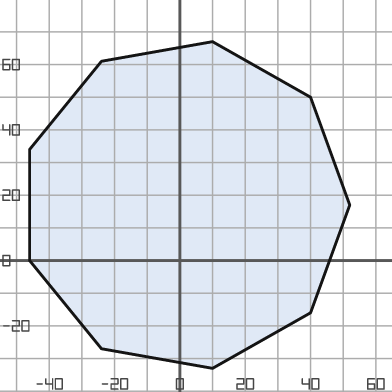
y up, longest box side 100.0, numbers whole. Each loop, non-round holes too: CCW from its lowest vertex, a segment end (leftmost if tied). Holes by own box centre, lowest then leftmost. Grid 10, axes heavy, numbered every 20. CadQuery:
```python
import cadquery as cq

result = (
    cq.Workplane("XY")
    .moveTo(10.0, -33.0)
    .lineTo(40.0, -16.0)
    .lineTo(52.0, 17.0)
    .lineTo(40.0, 50.0)
    .lineTo(10.0, 67.0)
    .lineTo(-24.0, 61.0)
    .lineTo(-46.0, 34.0)
    .lineTo(-46.0, 0.0)
    .lineTo(-24.0, -27.0)
    .close()
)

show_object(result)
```